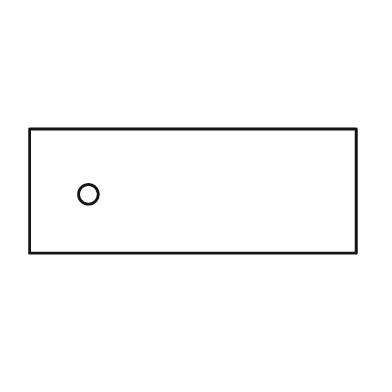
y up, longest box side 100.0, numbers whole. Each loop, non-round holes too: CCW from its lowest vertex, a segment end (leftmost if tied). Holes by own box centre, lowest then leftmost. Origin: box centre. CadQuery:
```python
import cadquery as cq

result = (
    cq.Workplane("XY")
    .moveTo(-50.0, -19.0)
    .lineTo(50.0, -19.0)
    .lineTo(50.0, 19.0)
    .lineTo(-50.0, 19.0)
    .close()
    .moveTo(-32.0, -1.0)
    .circle(3.0)
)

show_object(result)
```